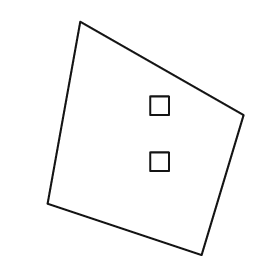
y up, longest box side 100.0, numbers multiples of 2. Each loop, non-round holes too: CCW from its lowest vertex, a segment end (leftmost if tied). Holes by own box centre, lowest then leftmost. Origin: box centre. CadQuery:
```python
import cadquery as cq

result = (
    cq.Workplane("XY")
    .moveTo(24.0, -50.0)
    .lineTo(42.0, 10.0)
    .lineTo(-28.0, 50.0)
    .lineTo(-42.0, -28.0)
    .close()
    .moveTo(2.0, -14.0)
    .lineTo(10.0, -14.0)
    .lineTo(10.0, -6.0)
    .lineTo(2.0, -6.0)
    .close()
    .moveTo(2.0, 10.0)
    .lineTo(10.0, 10.0)
    .lineTo(10.0, 18.0)
    .lineTo(2.0, 18.0)
    .close()
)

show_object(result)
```